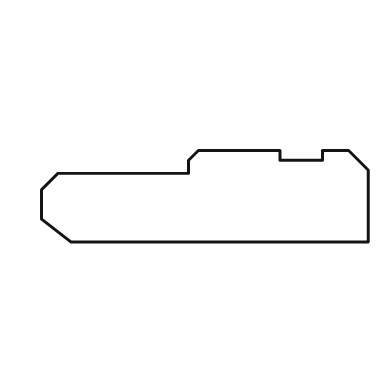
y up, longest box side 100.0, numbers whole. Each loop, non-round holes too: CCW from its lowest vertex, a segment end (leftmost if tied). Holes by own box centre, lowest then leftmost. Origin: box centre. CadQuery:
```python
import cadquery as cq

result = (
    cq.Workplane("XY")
    .moveTo(-41.0, -14.0)
    .lineTo(50.0, -14.0)
    .lineTo(50.0, 8.0)
    .lineTo(44.0, 14.0)
    .lineTo(36.0, 14.0)
    .lineTo(36.0, 11.0)
    .lineTo(23.0, 11.0)
    .lineTo(23.0, 14.0)
    .lineTo(-2.0, 14.0)
    .lineTo(-5.0, 11.0)
    .lineTo(-5.0, 7.0)
    .lineTo(-45.0, 7.0)
    .lineTo(-50.0, 2.0)
    .lineTo(-50.0, -7.0)
    .close()
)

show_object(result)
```